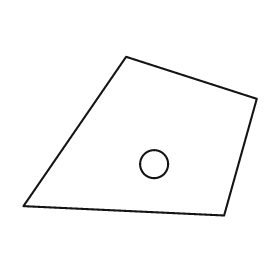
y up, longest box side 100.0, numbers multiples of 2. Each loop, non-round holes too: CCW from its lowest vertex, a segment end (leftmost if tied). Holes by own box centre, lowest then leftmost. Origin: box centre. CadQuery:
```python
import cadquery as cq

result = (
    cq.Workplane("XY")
    .moveTo(36.0, -34.0)
    .lineTo(50.0, 16.0)
    .lineTo(-6.0, 34.0)
    .lineTo(-50.0, -30.0)
    .close()
    .moveTo(6.0, -12.0)
    .circle(6.0)
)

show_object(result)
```